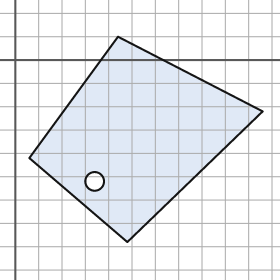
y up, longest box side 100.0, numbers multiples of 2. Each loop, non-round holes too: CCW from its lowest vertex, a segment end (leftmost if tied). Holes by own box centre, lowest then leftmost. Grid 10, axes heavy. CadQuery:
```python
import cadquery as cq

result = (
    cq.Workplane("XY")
    .moveTo(48.0, -78.0)
    .lineTo(106.0, -22.0)
    .lineTo(44.0, 10.0)
    .lineTo(6.0, -42.0)
    .close()
    .moveTo(34.0, -52.0)
    .circle(4.0)
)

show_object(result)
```